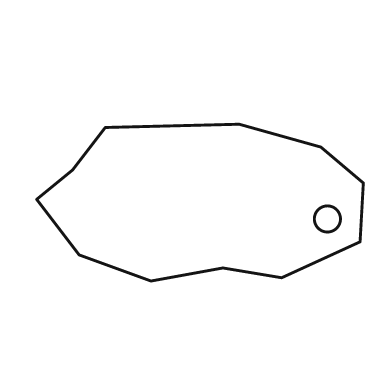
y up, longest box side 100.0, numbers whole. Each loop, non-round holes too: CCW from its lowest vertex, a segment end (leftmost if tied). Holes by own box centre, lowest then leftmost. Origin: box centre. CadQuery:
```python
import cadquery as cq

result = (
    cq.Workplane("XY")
    .moveTo(-15.0, -24.0)
    .lineTo(7.0, -20.0)
    .lineTo(25.0, -23.0)
    .lineTo(49.0, -12.0)
    .lineTo(50.0, 6.0)
    .lineTo(37.0, 17.0)
    .lineTo(12.0, 24.0)
    .lineTo(-29.0, 23.0)
    .lineTo(-39.0, 10.0)
    .lineTo(-50.0, 1.0)
    .lineTo(-37.0, -16.0)
    .close()
    .moveTo(39.0, -5.0)
    .circle(4.0)
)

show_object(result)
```